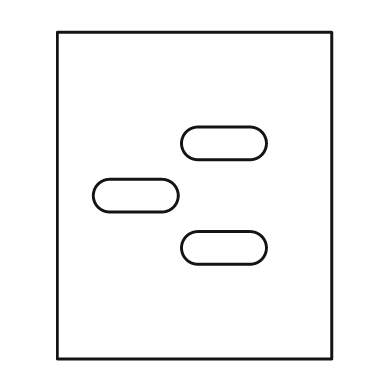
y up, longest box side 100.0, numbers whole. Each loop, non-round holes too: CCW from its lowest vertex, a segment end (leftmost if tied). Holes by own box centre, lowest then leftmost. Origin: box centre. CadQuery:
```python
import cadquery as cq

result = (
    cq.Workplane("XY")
    .moveTo(-42.0, -50.0)
    .lineTo(42.0, -50.0)
    .lineTo(42.0, 50.0)
    .lineTo(-42.0, 50.0)
    .close()
    .moveTo(1.0, -21.0)
    .lineTo(17.0, -21.0)
    .threePointArc((22.0, -16.0), (17.0, -11.0))
    .lineTo(1.0, -11.0)
    .threePointArc((-4.0, -16.0), (1.0, -21.0))
    .close()
    .moveTo(-26.0, -5.0)
    .lineTo(-10.0, -5.0)
    .threePointArc((-5.0, 0.0), (-10.0, 5.0))
    .lineTo(-26.0, 5.0)
    .threePointArc((-31.0, 0.0), (-26.0, -5.0))
    .close()
    .moveTo(1.0, 11.0)
    .lineTo(17.0, 11.0)
    .threePointArc((22.0, 16.0), (17.0, 21.0))
    .lineTo(1.0, 21.0)
    .threePointArc((-4.0, 16.0), (1.0, 11.0))
    .close()
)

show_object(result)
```